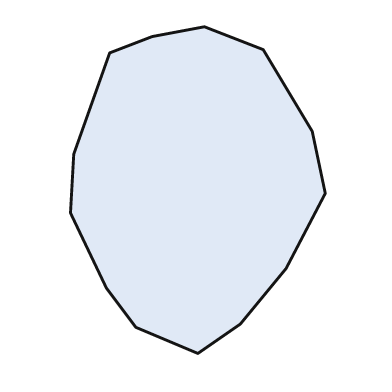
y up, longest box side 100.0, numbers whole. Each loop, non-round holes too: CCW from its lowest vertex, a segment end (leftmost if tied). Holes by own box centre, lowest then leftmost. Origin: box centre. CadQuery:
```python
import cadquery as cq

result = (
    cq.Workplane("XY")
    .moveTo(0.0, -50.0)
    .lineTo(13.0, -41.0)
    .lineTo(27.0, -24.0)
    .lineTo(39.0, -1.0)
    .lineTo(35.0, 18.0)
    .lineTo(20.0, 43.0)
    .lineTo(2.0, 50.0)
    .lineTo(-14.0, 47.0)
    .lineTo(-27.0, 42.0)
    .lineTo(-38.0, 11.0)
    .lineTo(-39.0, -7.0)
    .lineTo(-28.0, -30.0)
    .lineTo(-19.0, -42.0)
    .close()
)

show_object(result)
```